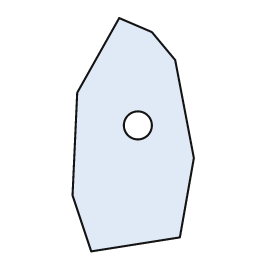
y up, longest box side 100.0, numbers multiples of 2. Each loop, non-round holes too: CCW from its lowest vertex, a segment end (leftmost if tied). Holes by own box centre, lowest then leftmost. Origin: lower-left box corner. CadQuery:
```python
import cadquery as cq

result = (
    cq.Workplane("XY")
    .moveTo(8.0, 0.0)
    .lineTo(46.0, 6.0)
    .lineTo(52.0, 40.0)
    .lineTo(44.0, 82.0)
    .lineTo(34.0, 94.0)
    .lineTo(20.0, 100.0)
    .lineTo(2.0, 68.0)
    .lineTo(0.0, 24.0)
    .close()
    .moveTo(28.0, 54.0)
    .circle(6.0)
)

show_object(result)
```